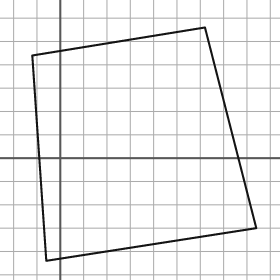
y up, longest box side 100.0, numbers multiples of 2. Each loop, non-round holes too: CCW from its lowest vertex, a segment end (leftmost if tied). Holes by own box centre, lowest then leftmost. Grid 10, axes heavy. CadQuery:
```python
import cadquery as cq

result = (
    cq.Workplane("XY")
    .moveTo(-6.0, -44.0)
    .lineTo(84.0, -30.0)
    .lineTo(62.0, 56.0)
    .lineTo(-12.0, 44.0)
    .close()
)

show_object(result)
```